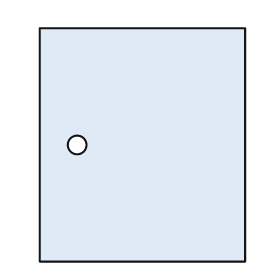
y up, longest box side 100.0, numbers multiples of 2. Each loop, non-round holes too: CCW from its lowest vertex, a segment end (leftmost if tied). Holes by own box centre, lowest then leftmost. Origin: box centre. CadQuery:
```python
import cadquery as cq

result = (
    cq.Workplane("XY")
    .moveTo(-44.0, -50.0)
    .lineTo(44.0, -50.0)
    .lineTo(44.0, 50.0)
    .lineTo(-44.0, 50.0)
    .close()
    .moveTo(-28.0, 0.0)
    .circle(4.0)
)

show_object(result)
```